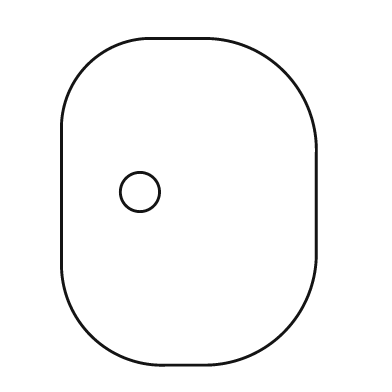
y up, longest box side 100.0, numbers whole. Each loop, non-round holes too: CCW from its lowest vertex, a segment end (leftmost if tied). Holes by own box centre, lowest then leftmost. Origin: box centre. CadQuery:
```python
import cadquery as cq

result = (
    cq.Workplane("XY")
    .moveTo(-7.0, -50.0)
    .lineTo(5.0, -50.0)
    .threePointArc((29.0, -40.0), (39.0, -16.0))
    .lineTo(39.0, 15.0)
    .threePointArc((29.0, 40.0), (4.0, 50.0))
    .lineTo(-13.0, 50.0)
    .threePointArc((-31.0, 42.0), (-39.0, 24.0))
    .lineTo(-39.0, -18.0)
    .threePointArc((-30.0, -41.0), (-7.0, -50.0))
    .close()
    .moveTo(-15.0, 3.0)
    .circle(6.0)
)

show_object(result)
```